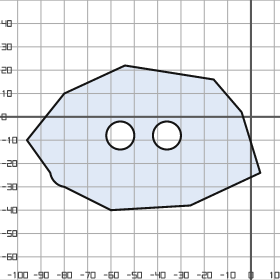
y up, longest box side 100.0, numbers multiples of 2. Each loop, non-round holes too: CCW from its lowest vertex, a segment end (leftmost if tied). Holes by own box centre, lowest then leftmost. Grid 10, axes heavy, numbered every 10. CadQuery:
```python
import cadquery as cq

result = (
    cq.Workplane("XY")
    .moveTo(-60.0, -40.0)
    .lineTo(-26.0, -38.0)
    .lineTo(4.0, -24.0)
    .lineTo(-4.0, 2.0)
    .lineTo(-16.0, 16.0)
    .lineTo(-54.0, 22.0)
    .lineTo(-80.0, 10.0)
    .lineTo(-96.0, -10.0)
    .lineTo(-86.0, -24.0)
    .threePointArc((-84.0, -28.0), (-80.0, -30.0))
    .close()
    .moveTo(-56.0, -8.0)
    .circle(6.0)
    .moveTo(-36.0, -8.0)
    .circle(6.0)
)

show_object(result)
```